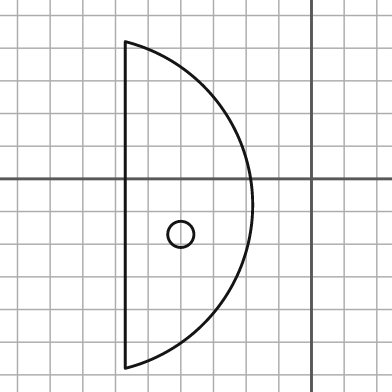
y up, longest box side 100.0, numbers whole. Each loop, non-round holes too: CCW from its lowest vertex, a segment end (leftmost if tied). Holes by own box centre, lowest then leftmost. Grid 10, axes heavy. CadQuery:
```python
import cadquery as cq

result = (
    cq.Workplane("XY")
    .moveTo(-57.0, -58.0)
    .threePointArc((-18.0, -8.0), (-57.0, 42.0))
    .close()
    .moveTo(-40.0, -17.0)
    .circle(4.0)
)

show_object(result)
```